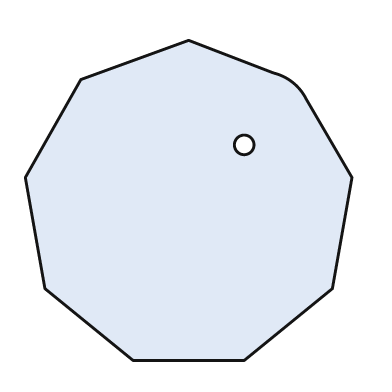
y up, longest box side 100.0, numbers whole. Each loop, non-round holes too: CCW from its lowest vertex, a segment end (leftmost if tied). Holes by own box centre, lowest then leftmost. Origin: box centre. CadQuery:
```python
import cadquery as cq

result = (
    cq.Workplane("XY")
    .moveTo(-17.0, -49.0)
    .lineTo(17.0, -49.0)
    .lineTo(44.0, -27.0)
    .lineTo(50.0, 7.0)
    .lineTo(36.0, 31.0)
    .threePointArc((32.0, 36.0), (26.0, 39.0))
    .lineTo(0.0, 49.0)
    .lineTo(-33.0, 37.0)
    .lineTo(-50.0, 7.0)
    .lineTo(-44.0, -27.0)
    .close()
    .moveTo(17.0, 17.0)
    .circle(3.0)
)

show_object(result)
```